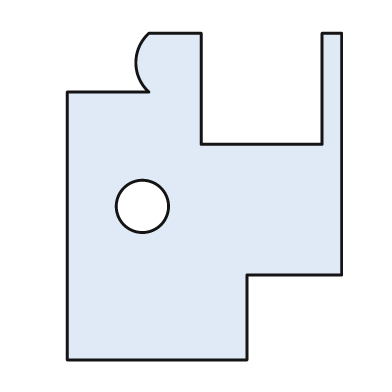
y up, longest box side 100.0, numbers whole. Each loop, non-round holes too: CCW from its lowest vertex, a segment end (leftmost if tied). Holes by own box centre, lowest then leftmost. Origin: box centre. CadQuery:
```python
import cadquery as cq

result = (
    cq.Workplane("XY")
    .moveTo(-42.0, -50.0)
    .lineTo(13.0, -50.0)
    .lineTo(13.0, -24.0)
    .lineTo(42.0, -24.0)
    .lineTo(42.0, 50.0)
    .lineTo(36.0, 50.0)
    .lineTo(36.0, 16.0)
    .lineTo(-1.0, 16.0)
    .lineTo(-1.0, 50.0)
    .lineTo(-17.0, 50.0)
    .threePointArc((-21.0, 41.0), (-17.0, 32.0))
    .lineTo(-42.0, 32.0)
    .close()
    .moveTo(-19.0, -3.0)
    .circle(8.0)
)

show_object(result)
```